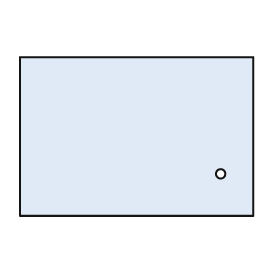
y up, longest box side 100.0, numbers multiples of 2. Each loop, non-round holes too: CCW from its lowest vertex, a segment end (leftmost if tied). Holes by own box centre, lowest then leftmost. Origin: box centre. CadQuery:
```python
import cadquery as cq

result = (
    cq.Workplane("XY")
    .moveTo(-50.0, -34.0)
    .lineTo(50.0, -34.0)
    .lineTo(50.0, 34.0)
    .lineTo(-50.0, 34.0)
    .close()
    .moveTo(36.0, -16.0)
    .circle(2.0)
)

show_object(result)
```